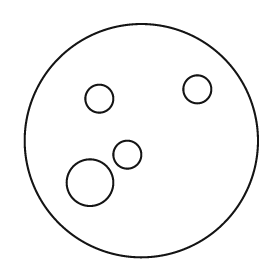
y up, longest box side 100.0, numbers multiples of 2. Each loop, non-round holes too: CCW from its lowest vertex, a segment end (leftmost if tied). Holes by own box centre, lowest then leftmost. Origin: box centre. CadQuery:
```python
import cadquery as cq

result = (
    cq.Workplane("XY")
    .moveTo(0.0, 0.0)
    .circle(50.0)
    .moveTo(-22.0, -18.0)
    .circle(10.0)
    .moveTo(-6.0, -6.0)
    .circle(6.0)
    .moveTo(-18.0, 18.0)
    .circle(6.0)
    .moveTo(24.0, 22.0)
    .circle(6.0)
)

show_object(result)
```